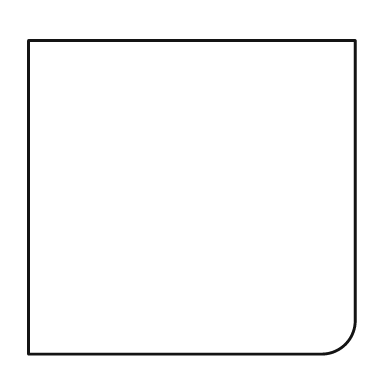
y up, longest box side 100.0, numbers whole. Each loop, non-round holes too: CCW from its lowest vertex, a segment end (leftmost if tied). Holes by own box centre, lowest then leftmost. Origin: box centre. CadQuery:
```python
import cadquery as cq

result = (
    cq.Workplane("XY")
    .moveTo(-50.0, -48.0)
    .lineTo(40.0, -48.0)
    .threePointArc((47.0, -45.0), (50.0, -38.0))
    .lineTo(50.0, 48.0)
    .lineTo(-50.0, 48.0)
    .close()
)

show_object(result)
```